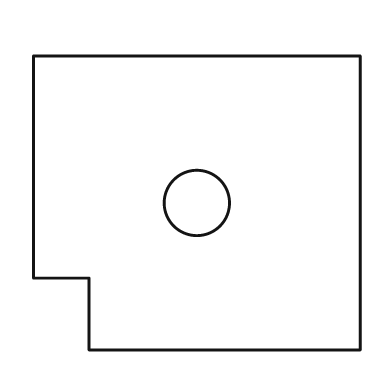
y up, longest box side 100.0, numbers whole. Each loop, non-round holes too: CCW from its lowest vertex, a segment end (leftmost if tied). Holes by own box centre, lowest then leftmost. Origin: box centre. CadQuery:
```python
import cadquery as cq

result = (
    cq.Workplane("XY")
    .moveTo(-33.0, -45.0)
    .lineTo(50.0, -45.0)
    .lineTo(50.0, 45.0)
    .lineTo(-50.0, 45.0)
    .lineTo(-50.0, -23.0)
    .lineTo(-33.0, -23.0)
    .close()
    .moveTo(0.0, 0.0)
    .circle(10.0)
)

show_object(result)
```